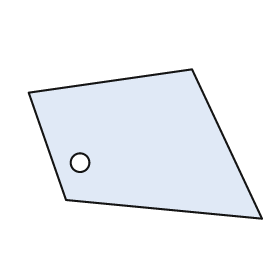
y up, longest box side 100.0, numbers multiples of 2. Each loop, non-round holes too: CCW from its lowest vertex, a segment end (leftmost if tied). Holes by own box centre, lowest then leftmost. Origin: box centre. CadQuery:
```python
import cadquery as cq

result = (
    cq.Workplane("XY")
    .moveTo(50.0, -32.0)
    .lineTo(20.0, 32.0)
    .lineTo(-50.0, 22.0)
    .lineTo(-34.0, -24.0)
    .close()
    .moveTo(-28.0, -8.0)
    .circle(4.0)
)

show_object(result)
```